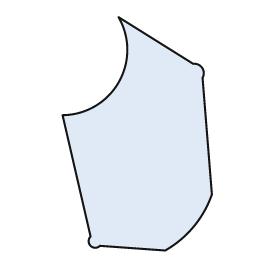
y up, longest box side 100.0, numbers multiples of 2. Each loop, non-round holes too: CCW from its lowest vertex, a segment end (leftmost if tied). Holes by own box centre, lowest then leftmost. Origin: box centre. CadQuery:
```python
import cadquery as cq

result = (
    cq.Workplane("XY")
    .moveTo(12.0, -50.0)
    .threePointArc((24.0, -40.0), (32.0, -26.0))
    .lineTo(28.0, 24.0)
    .threePointArc((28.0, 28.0), (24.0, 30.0))
    .lineTo(-8.0, 50.0)
    .threePointArc((-8.0, 22.0), (-32.0, 8.0))
    .lineTo(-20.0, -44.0)
    .threePointArc((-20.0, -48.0), (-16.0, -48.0))
    .close()
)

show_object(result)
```